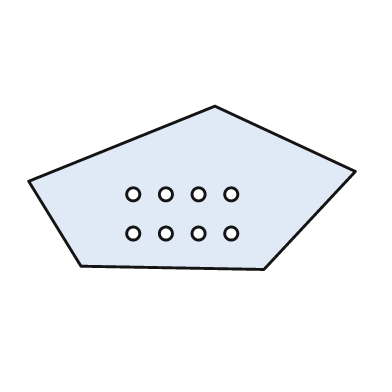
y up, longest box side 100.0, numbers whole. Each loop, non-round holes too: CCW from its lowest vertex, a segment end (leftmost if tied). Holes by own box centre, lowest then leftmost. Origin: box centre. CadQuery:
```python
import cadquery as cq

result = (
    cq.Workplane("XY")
    .moveTo(22.0, -25.0)
    .lineTo(50.0, 5.0)
    .lineTo(7.0, 25.0)
    .lineTo(-50.0, 2.0)
    .lineTo(-34.0, -24.0)
    .close()
    .moveTo(-18.0, -14.0)
    .circle(2.0)
    .moveTo(-8.0, -14.0)
    .circle(2.0)
    .moveTo(2.0, -14.0)
    .circle(2.0)
    .moveTo(12.0, -14.0)
    .circle(2.0)
    .moveTo(-18.0, -2.0)
    .circle(2.0)
    .moveTo(-8.0, -2.0)
    .circle(2.0)
    .moveTo(2.0, -2.0)
    .circle(2.0)
    .moveTo(12.0, -2.0)
    .circle(2.0)
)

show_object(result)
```